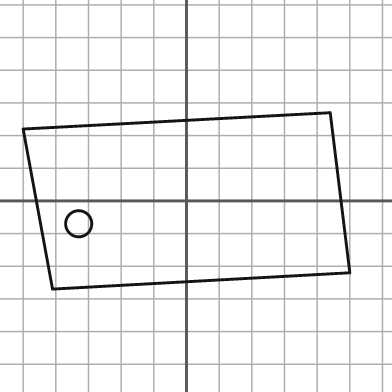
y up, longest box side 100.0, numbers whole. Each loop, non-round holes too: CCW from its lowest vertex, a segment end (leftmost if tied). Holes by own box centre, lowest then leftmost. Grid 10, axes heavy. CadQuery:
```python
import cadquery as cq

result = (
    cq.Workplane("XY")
    .moveTo(-41.0, -27.0)
    .lineTo(50.0, -22.0)
    .lineTo(44.0, 27.0)
    .lineTo(-50.0, 22.0)
    .close()
    .moveTo(-33.0, -7.0)
    .circle(4.0)
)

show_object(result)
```